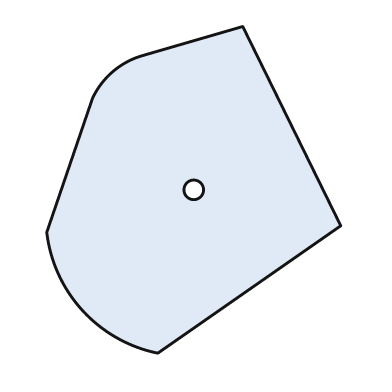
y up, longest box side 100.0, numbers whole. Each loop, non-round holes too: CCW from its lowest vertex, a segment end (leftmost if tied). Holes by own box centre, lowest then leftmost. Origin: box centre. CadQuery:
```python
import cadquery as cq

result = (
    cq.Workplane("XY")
    .moveTo(-11.0, -50.0)
    .lineTo(45.0, -11.0)
    .lineTo(15.0, 50.0)
    .lineTo(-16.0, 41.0)
    .threePointArc((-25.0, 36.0), (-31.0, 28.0))
    .lineTo(-45.0, -13.0)
    .threePointArc((-34.0, -37.0), (-11.0, -50.0))
    .close()
    .moveTo(0.0, 0.0)
    .circle(3.0)
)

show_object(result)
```